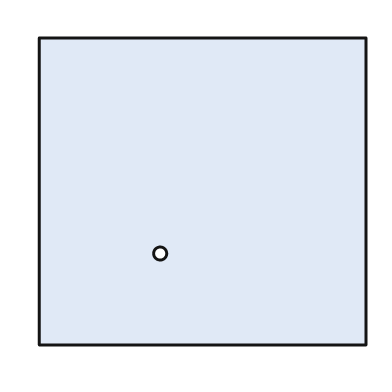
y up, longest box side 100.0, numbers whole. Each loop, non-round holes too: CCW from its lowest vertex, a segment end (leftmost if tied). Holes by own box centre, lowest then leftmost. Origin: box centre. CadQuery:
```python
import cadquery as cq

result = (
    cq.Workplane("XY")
    .moveTo(-50.0, -47.0)
    .lineTo(50.0, -47.0)
    .lineTo(50.0, 47.0)
    .lineTo(-50.0, 47.0)
    .close()
    .moveTo(-13.0, -19.0)
    .circle(2.0)
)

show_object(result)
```